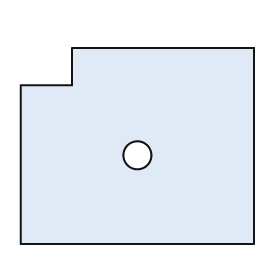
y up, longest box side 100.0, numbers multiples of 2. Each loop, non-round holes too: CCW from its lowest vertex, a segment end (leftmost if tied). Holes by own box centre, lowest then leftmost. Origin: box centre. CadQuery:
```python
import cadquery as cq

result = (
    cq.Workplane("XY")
    .moveTo(-50.0, -42.0)
    .lineTo(50.0, -42.0)
    .lineTo(50.0, 42.0)
    .lineTo(-28.0, 42.0)
    .lineTo(-28.0, 26.0)
    .lineTo(-50.0, 26.0)
    .close()
    .moveTo(0.0, -4.0)
    .circle(6.0)
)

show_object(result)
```